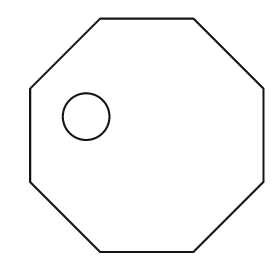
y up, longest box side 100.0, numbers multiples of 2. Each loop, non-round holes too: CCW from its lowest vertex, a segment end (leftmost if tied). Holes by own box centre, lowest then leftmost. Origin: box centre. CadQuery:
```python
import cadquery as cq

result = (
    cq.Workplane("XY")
    .moveTo(-20.0, -50.0)
    .lineTo(20.0, -50.0)
    .lineTo(50.0, -20.0)
    .lineTo(50.0, 20.0)
    .lineTo(20.0, 50.0)
    .lineTo(-20.0, 50.0)
    .lineTo(-50.0, 20.0)
    .lineTo(-50.0, -20.0)
    .close()
    .moveTo(-26.0, 8.0)
    .circle(10.0)
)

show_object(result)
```